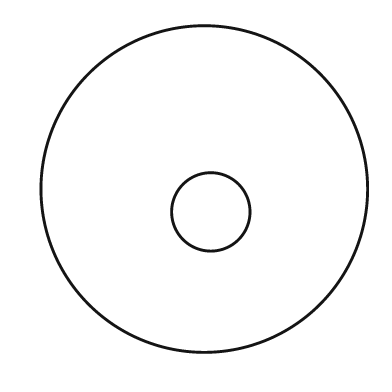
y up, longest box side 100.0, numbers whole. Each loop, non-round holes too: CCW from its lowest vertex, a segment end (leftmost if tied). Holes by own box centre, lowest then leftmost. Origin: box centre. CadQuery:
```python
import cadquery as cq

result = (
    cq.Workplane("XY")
    .moveTo(0.0, 0.0)
    .circle(50.0)
    .moveTo(2.0, -7.0)
    .circle(12.0)
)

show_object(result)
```